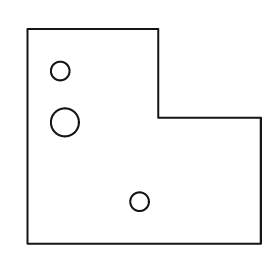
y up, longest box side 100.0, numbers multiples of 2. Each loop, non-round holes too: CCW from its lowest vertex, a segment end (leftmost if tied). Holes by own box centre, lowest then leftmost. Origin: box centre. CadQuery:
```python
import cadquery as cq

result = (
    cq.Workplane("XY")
    .moveTo(-50.0, -46.0)
    .lineTo(50.0, -46.0)
    .lineTo(50.0, 8.0)
    .lineTo(6.0, 8.0)
    .lineTo(6.0, 46.0)
    .lineTo(-50.0, 46.0)
    .close()
    .moveTo(-2.0, -28.0)
    .circle(4.0)
    .moveTo(-34.0, 6.0)
    .circle(6.0)
    .moveTo(-36.0, 28.0)
    .circle(4.0)
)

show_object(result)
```